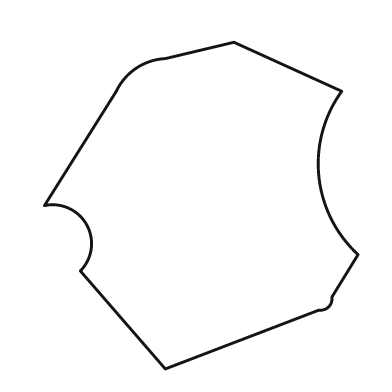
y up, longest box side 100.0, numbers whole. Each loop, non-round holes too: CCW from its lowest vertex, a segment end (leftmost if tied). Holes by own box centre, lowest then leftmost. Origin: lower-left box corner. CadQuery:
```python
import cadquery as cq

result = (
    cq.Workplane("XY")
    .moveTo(37.0, 0.0)
    .lineTo(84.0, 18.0)
    .threePointArc((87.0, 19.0), (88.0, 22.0))
    .lineTo(96.0, 35.0)
    .threePointArc((84.0, 59.0), (91.0, 85.0))
    .lineTo(58.0, 100.0)
    .lineTo(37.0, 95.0)
    .threePointArc((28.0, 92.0), (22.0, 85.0))
    .lineTo(0.0, 50.0)
    .threePointArc((13.0, 44.0), (11.0, 30.0))
    .close()
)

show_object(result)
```